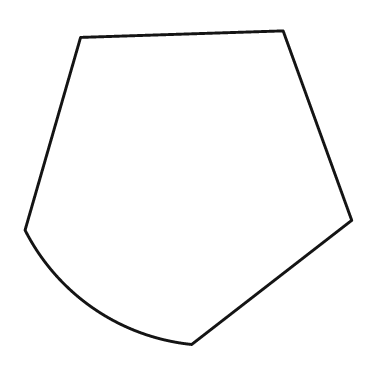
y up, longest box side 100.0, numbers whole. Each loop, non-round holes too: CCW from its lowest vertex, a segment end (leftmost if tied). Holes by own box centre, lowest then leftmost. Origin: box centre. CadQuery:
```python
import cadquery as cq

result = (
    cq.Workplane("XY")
    .moveTo(1.0, -48.0)
    .lineTo(50.0, -10.0)
    .lineTo(29.0, 48.0)
    .lineTo(-33.0, 46.0)
    .lineTo(-50.0, -13.0)
    .threePointArc((-29.0, -37.0), (1.0, -48.0))
    .close()
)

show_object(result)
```